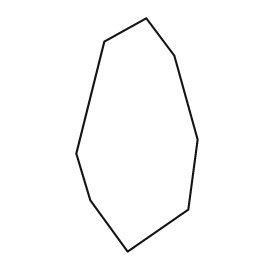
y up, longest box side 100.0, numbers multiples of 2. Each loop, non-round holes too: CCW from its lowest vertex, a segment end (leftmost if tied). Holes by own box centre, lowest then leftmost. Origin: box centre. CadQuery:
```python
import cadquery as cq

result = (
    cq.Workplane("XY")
    .moveTo(-4.0, -50.0)
    .lineTo(22.0, -32.0)
    .lineTo(26.0, -2.0)
    .lineTo(16.0, 34.0)
    .lineTo(4.0, 50.0)
    .lineTo(-14.0, 40.0)
    .lineTo(-26.0, -8.0)
    .lineTo(-20.0, -28.0)
    .close()
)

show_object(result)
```